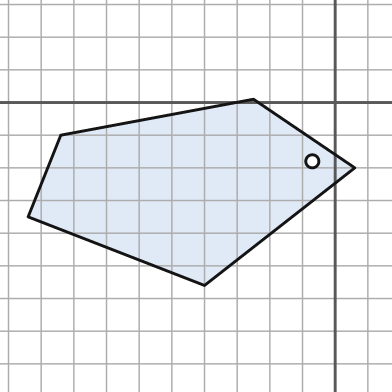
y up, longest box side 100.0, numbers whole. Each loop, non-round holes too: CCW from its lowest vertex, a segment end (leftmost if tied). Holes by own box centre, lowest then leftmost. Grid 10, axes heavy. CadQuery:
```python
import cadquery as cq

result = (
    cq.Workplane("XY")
    .moveTo(-40.0, -56.0)
    .lineTo(6.0, -20.0)
    .lineTo(-25.0, 1.0)
    .lineTo(-84.0, -10.0)
    .lineTo(-94.0, -35.0)
    .close()
    .moveTo(-7.0, -18.0)
    .circle(2.0)
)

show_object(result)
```